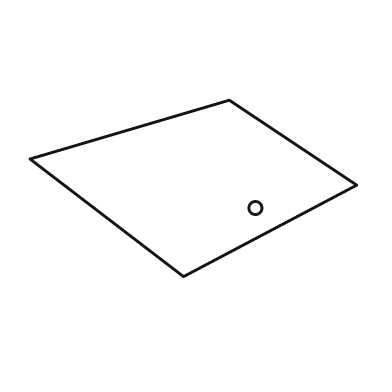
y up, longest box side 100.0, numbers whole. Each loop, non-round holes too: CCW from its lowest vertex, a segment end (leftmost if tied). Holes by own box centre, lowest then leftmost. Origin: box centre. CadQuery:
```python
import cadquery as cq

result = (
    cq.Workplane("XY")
    .moveTo(-3.0, -27.0)
    .lineTo(50.0, 1.0)
    .lineTo(11.0, 27.0)
    .lineTo(-50.0, 9.0)
    .close()
    .moveTo(19.0, -6.0)
    .circle(2.0)
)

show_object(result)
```